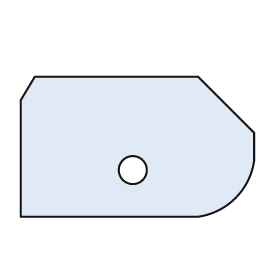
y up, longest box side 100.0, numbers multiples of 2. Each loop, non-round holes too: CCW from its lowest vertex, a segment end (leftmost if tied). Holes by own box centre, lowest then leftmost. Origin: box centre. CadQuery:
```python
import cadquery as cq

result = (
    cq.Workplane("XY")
    .moveTo(-50.0, -30.0)
    .lineTo(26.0, -30.0)
    .threePointArc((42.0, -22.0), (50.0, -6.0))
    .lineTo(50.0, 6.0)
    .lineTo(26.0, 30.0)
    .lineTo(-44.0, 30.0)
    .lineTo(-50.0, 20.0)
    .close()
    .moveTo(-2.0, -10.0)
    .circle(6.0)
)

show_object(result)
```